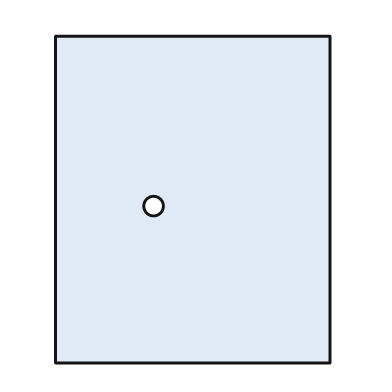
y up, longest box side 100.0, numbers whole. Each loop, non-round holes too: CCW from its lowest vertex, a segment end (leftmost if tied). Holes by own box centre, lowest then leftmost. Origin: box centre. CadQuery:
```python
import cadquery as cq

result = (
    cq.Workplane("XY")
    .moveTo(-42.0, -50.0)
    .lineTo(42.0, -50.0)
    .lineTo(42.0, 50.0)
    .lineTo(-42.0, 50.0)
    .close()
    .moveTo(-12.0, -2.0)
    .circle(3.0)
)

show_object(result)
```